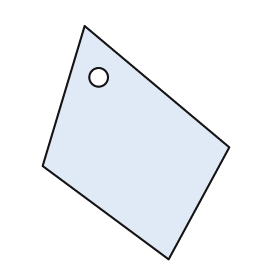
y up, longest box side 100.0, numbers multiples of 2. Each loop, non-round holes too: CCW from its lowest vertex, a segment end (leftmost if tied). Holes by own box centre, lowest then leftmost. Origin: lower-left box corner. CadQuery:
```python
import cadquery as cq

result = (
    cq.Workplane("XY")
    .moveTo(54.0, 0.0)
    .lineTo(80.0, 48.0)
    .lineTo(18.0, 100.0)
    .lineTo(0.0, 40.0)
    .close()
    .moveTo(24.0, 78.0)
    .circle(4.0)
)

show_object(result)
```